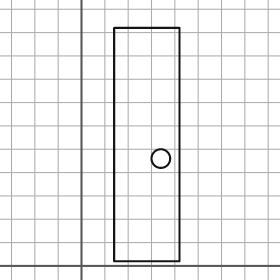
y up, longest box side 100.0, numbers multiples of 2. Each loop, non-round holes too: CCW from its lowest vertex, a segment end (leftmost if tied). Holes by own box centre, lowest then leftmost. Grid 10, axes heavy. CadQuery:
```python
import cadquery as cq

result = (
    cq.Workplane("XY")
    .moveTo(14.0, 2.0)
    .lineTo(42.0, 2.0)
    .lineTo(42.0, 102.0)
    .lineTo(14.0, 102.0)
    .close()
    .moveTo(34.0, 46.0)
    .circle(4.0)
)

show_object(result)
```